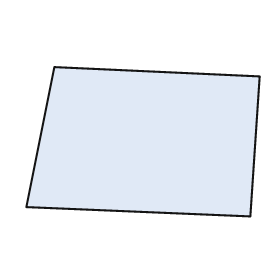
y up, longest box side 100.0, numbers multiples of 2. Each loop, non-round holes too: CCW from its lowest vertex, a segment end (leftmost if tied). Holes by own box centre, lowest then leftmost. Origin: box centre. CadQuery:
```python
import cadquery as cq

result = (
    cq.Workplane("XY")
    .moveTo(46.0, -32.0)
    .lineTo(50.0, 28.0)
    .lineTo(-38.0, 32.0)
    .lineTo(-50.0, -28.0)
    .close()
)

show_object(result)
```